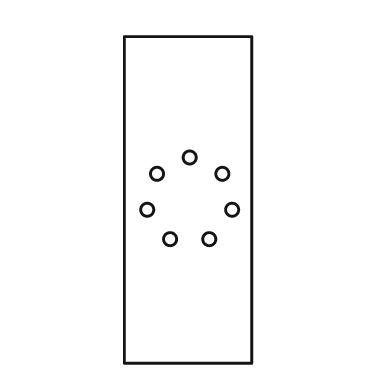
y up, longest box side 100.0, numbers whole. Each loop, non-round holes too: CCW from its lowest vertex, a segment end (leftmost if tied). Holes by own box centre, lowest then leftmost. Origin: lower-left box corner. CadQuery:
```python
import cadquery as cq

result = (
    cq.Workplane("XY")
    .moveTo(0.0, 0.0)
    .lineTo(39.0, 0.0)
    .lineTo(39.0, 100.0)
    .lineTo(0.0, 100.0)
    .close()
    .moveTo(14.0, 38.0)
    .circle(2.0)
    .moveTo(26.0, 38.0)
    .circle(2.0)
    .moveTo(7.0, 47.0)
    .circle(2.0)
    .moveTo(33.0, 47.0)
    .circle(2.0)
    .moveTo(10.0, 58.0)
    .circle(2.0)
    .moveTo(30.0, 58.0)
    .circle(2.0)
    .moveTo(20.0, 63.0)
    .circle(2.0)
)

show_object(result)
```